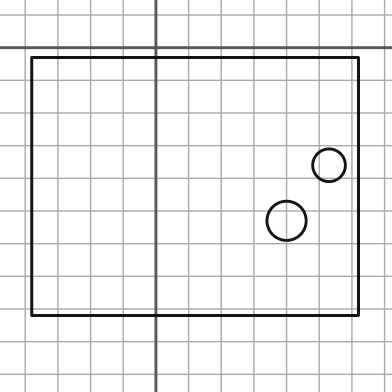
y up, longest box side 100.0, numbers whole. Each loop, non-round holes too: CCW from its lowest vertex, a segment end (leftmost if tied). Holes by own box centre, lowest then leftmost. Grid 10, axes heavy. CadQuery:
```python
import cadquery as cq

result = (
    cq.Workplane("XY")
    .moveTo(-38.0, -82.0)
    .lineTo(62.0, -82.0)
    .lineTo(62.0, -3.0)
    .lineTo(-38.0, -3.0)
    .close()
    .moveTo(40.0, -53.0)
    .circle(6.0)
    .moveTo(53.0, -36.0)
    .circle(5.0)
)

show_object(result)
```